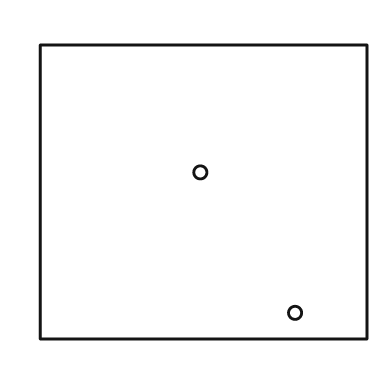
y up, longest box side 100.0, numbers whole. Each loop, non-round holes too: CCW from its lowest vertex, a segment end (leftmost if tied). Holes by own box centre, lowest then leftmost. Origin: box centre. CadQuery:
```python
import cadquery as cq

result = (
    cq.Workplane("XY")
    .moveTo(-50.0, -45.0)
    .lineTo(50.0, -45.0)
    .lineTo(50.0, 45.0)
    .lineTo(-50.0, 45.0)
    .close()
    .moveTo(28.0, -37.0)
    .circle(2.0)
    .moveTo(-1.0, 6.0)
    .circle(2.0)
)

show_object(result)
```